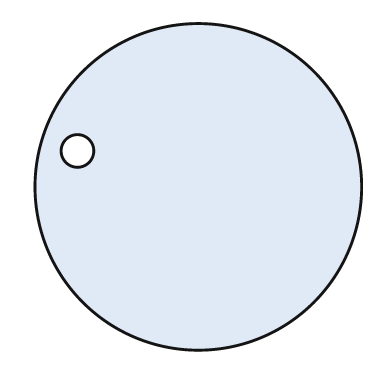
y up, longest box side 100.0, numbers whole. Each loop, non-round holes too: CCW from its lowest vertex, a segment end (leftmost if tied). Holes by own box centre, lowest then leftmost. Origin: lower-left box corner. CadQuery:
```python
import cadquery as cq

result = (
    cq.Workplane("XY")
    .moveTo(50.0, 50.0)
    .circle(50.0)
    .moveTo(13.0, 61.0)
    .circle(5.0)
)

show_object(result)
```